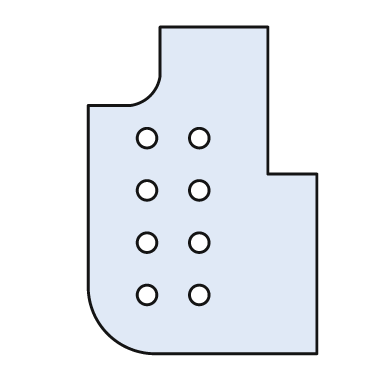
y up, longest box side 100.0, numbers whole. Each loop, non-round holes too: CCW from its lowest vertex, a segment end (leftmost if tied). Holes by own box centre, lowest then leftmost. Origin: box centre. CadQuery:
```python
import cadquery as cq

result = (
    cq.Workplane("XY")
    .moveTo(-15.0, -50.0)
    .lineTo(35.0, -50.0)
    .lineTo(35.0, 5.0)
    .lineTo(20.0, 5.0)
    .lineTo(20.0, 50.0)
    .lineTo(-13.0, 50.0)
    .lineTo(-13.0, 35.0)
    .threePointArc((-16.0, 29.0), (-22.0, 26.0))
    .lineTo(-35.0, 26.0)
    .lineTo(-35.0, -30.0)
    .threePointArc((-29.0, -44.0), (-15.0, -50.0))
    .close()
    .moveTo(-17.0, -32.0)
    .circle(3.0)
    .moveTo(-1.0, -32.0)
    .circle(3.0)
    .moveTo(-17.0, -16.0)
    .circle(3.0)
    .moveTo(-1.0, -16.0)
    .circle(3.0)
    .moveTo(-17.0, 0.0)
    .circle(3.0)
    .moveTo(-1.0, 0.0)
    .circle(3.0)
    .moveTo(-17.0, 16.0)
    .circle(3.0)
    .moveTo(-1.0, 16.0)
    .circle(3.0)
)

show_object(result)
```